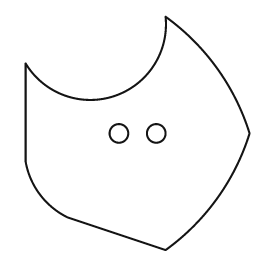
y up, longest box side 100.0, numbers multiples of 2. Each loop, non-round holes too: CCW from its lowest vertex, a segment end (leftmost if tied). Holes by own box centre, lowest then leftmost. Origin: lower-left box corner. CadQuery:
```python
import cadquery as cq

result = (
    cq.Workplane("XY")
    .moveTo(60.0, 0.0)
    .threePointArc((82.0, 22.0), (96.0, 50.0))
    .threePointArc((82.0, 78.0), (60.0, 100.0))
    .threePointArc((38.0, 66.0), (0.0, 80.0))
    .lineTo(0.0, 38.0)
    .threePointArc((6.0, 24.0), (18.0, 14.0))
    .close()
    .moveTo(40.0, 50.0)
    .circle(4.0)
    .moveTo(56.0, 50.0)
    .circle(4.0)
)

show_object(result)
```